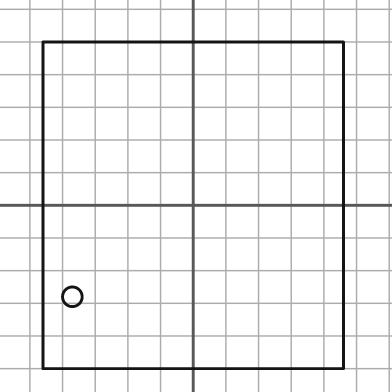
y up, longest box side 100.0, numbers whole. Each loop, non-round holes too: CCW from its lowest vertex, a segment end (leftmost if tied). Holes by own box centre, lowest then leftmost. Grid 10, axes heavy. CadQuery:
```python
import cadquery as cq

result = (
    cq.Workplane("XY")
    .moveTo(-46.0, -50.0)
    .lineTo(46.0, -50.0)
    .lineTo(46.0, 50.0)
    .lineTo(-46.0, 50.0)
    .close()
    .moveTo(-37.0, -28.0)
    .circle(3.0)
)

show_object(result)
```